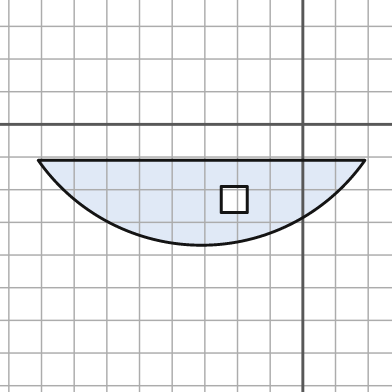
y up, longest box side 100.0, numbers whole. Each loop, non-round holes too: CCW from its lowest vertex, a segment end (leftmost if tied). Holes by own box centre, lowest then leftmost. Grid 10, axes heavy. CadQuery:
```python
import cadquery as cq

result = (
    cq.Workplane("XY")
    .moveTo(-81.0, -11.0)
    .threePointArc((-31.0, -37.0), (19.0, -11.0))
    .close()
    .moveTo(-25.0, -27.0)
    .lineTo(-17.0, -27.0)
    .lineTo(-17.0, -19.0)
    .lineTo(-25.0, -19.0)
    .close()
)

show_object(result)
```